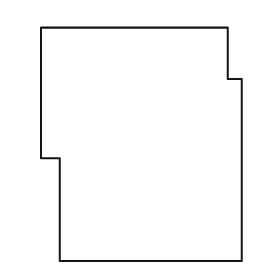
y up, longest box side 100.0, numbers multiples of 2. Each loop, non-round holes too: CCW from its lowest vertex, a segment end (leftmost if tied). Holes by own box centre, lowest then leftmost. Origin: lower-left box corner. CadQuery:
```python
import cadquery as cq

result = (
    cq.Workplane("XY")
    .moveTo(8.0, 0.0)
    .lineTo(86.0, 0.0)
    .lineTo(86.0, 78.0)
    .lineTo(80.0, 78.0)
    .lineTo(80.0, 100.0)
    .lineTo(0.0, 100.0)
    .lineTo(0.0, 44.0)
    .lineTo(8.0, 44.0)
    .close()
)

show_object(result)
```